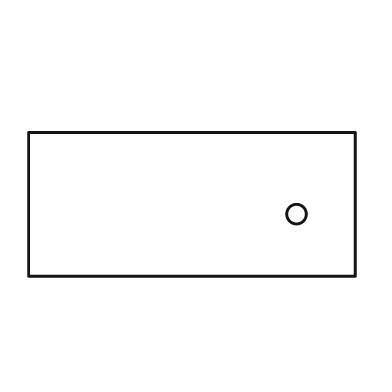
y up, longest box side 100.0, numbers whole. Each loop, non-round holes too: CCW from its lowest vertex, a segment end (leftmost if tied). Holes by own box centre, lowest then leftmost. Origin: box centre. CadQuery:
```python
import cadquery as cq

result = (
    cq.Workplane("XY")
    .moveTo(-50.0, -22.0)
    .lineTo(50.0, -22.0)
    .lineTo(50.0, 22.0)
    .lineTo(-50.0, 22.0)
    .close()
    .moveTo(32.0, -3.0)
    .circle(3.0)
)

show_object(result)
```